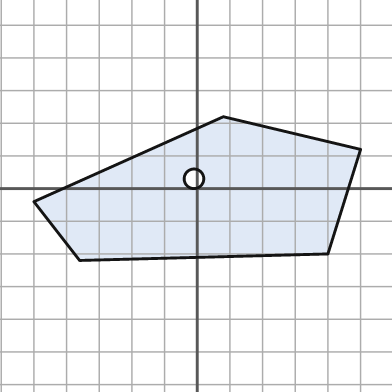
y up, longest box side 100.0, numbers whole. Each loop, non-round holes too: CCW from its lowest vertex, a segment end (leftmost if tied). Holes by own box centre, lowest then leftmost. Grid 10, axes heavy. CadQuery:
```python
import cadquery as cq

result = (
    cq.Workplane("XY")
    .moveTo(-36.0, -22.0)
    .lineTo(40.0, -20.0)
    .lineTo(50.0, 12.0)
    .lineTo(8.0, 22.0)
    .lineTo(-50.0, -4.0)
    .close()
    .moveTo(-1.0, 3.0)
    .circle(3.0)
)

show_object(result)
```